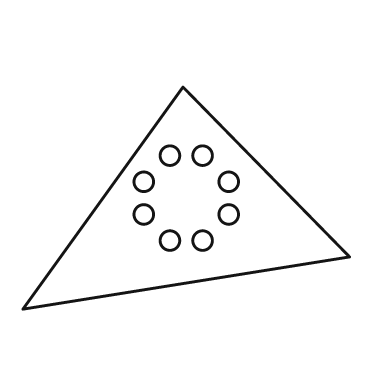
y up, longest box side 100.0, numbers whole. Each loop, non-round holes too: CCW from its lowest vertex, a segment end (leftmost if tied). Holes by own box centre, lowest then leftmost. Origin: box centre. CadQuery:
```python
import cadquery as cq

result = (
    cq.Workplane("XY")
    .moveTo(-50.0, -34.0)
    .lineTo(50.0, -18.0)
    .lineTo(-1.0, 34.0)
    .close()
    .moveTo(-5.0, -13.0)
    .circle(3.0)
    .moveTo(5.0, -13.0)
    .circle(3.0)
    .moveTo(-13.0, -5.0)
    .circle(3.0)
    .moveTo(13.0, -5.0)
    .circle(3.0)
    .moveTo(-13.0, 5.0)
    .circle(3.0)
    .moveTo(13.0, 5.0)
    .circle(3.0)
    .moveTo(-5.0, 13.0)
    .circle(3.0)
    .moveTo(5.0, 13.0)
    .circle(3.0)
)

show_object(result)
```